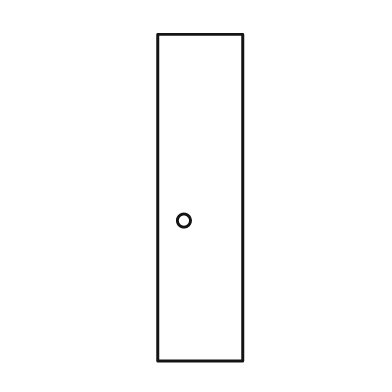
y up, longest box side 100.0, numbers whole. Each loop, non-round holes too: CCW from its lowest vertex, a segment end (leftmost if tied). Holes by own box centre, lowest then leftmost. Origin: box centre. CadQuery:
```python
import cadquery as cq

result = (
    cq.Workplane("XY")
    .moveTo(-13.0, -50.0)
    .lineTo(13.0, -50.0)
    .lineTo(13.0, 50.0)
    .lineTo(-13.0, 50.0)
    .close()
    .moveTo(-5.0, -7.0)
    .circle(2.0)
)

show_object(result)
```